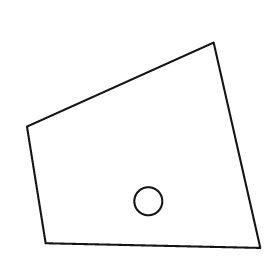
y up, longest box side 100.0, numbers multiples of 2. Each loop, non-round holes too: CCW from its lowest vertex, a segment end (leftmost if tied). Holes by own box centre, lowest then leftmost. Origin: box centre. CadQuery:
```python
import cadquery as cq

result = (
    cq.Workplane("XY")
    .moveTo(50.0, -44.0)
    .lineTo(30.0, 44.0)
    .lineTo(-50.0, 8.0)
    .lineTo(-42.0, -42.0)
    .close()
    .moveTo(2.0, -24.0)
    .circle(6.0)
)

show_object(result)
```